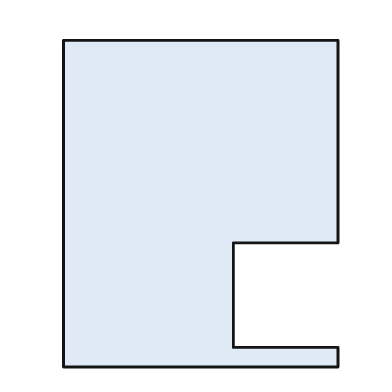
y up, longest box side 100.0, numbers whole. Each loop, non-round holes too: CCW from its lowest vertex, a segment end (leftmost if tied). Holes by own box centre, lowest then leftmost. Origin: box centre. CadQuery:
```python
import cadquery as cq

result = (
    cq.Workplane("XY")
    .moveTo(-42.0, -50.0)
    .lineTo(42.0, -50.0)
    .lineTo(42.0, -44.0)
    .lineTo(10.0, -44.0)
    .lineTo(10.0, -12.0)
    .lineTo(42.0, -12.0)
    .lineTo(42.0, 50.0)
    .lineTo(-42.0, 50.0)
    .close()
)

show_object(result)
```